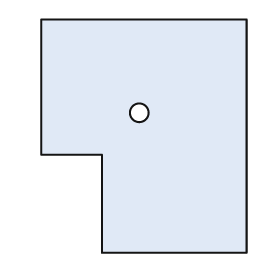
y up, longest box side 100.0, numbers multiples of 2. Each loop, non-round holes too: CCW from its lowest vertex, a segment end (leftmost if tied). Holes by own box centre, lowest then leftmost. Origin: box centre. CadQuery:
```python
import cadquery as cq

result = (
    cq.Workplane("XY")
    .moveTo(-18.0, -50.0)
    .lineTo(44.0, -50.0)
    .lineTo(44.0, 50.0)
    .lineTo(-44.0, 50.0)
    .lineTo(-44.0, -8.0)
    .lineTo(-18.0, -8.0)
    .close()
    .moveTo(-2.0, 10.0)
    .circle(4.0)
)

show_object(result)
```